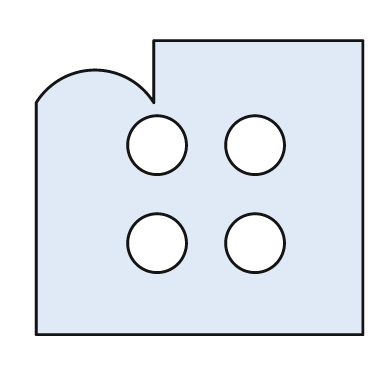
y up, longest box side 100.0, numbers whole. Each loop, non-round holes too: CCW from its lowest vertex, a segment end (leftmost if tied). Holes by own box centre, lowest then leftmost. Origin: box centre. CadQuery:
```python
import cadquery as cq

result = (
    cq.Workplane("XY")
    .moveTo(-50.0, -45.0)
    .lineTo(50.0, -45.0)
    .lineTo(50.0, 45.0)
    .lineTo(-14.0, 45.0)
    .lineTo(-14.0, 26.0)
    .threePointArc((-32.0, 36.0), (-50.0, 26.0))
    .close()
    .moveTo(-13.0, -17.0)
    .circle(9.0)
    .moveTo(17.0, -17.0)
    .circle(9.0)
    .moveTo(-13.0, 13.0)
    .circle(9.0)
    .moveTo(17.0, 13.0)
    .circle(9.0)
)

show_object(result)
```